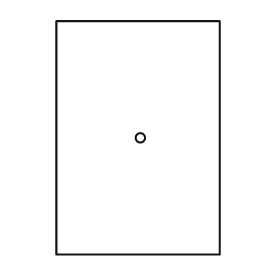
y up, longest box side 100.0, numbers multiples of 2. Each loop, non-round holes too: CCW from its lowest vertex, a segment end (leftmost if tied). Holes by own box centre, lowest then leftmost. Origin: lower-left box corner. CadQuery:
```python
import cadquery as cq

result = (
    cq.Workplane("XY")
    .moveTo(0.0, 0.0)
    .lineTo(70.0, 0.0)
    .lineTo(70.0, 100.0)
    .lineTo(0.0, 100.0)
    .close()
    .moveTo(36.0, 50.0)
    .circle(2.0)
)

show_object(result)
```